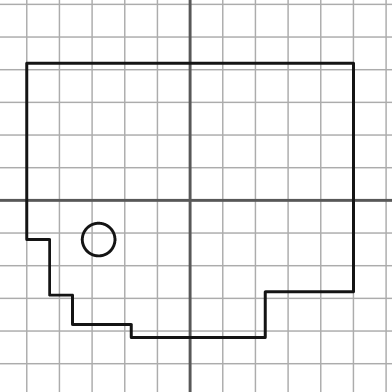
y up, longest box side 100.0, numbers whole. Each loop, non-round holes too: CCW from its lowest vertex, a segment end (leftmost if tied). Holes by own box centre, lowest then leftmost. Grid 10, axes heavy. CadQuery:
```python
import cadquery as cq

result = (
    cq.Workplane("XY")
    .moveTo(-18.0, -42.0)
    .lineTo(23.0, -42.0)
    .lineTo(23.0, -28.0)
    .lineTo(50.0, -28.0)
    .lineTo(50.0, 42.0)
    .lineTo(-50.0, 42.0)
    .lineTo(-50.0, -12.0)
    .lineTo(-43.0, -12.0)
    .lineTo(-43.0, -29.0)
    .lineTo(-36.0, -29.0)
    .lineTo(-36.0, -38.0)
    .lineTo(-18.0, -38.0)
    .close()
    .moveTo(-28.0, -12.0)
    .circle(5.0)
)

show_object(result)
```